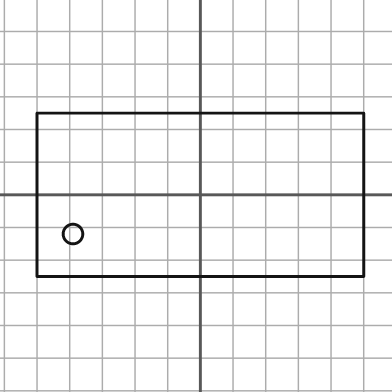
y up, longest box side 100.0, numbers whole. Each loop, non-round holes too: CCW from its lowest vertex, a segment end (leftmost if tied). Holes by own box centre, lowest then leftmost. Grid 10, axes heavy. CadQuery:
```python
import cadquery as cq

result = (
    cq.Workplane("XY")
    .moveTo(-50.0, -25.0)
    .lineTo(50.0, -25.0)
    .lineTo(50.0, 25.0)
    .lineTo(-50.0, 25.0)
    .close()
    .moveTo(-39.0, -12.0)
    .circle(3.0)
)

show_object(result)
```